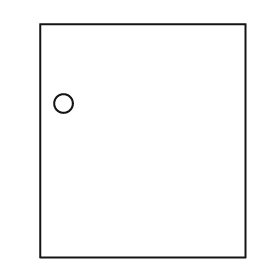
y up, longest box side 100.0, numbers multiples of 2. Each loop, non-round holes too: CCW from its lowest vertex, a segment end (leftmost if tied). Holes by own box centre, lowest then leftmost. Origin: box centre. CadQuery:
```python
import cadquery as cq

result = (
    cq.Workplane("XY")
    .moveTo(-44.0, -50.0)
    .lineTo(44.0, -50.0)
    .lineTo(44.0, 50.0)
    .lineTo(-44.0, 50.0)
    .close()
    .moveTo(-34.0, 16.0)
    .circle(4.0)
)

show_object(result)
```